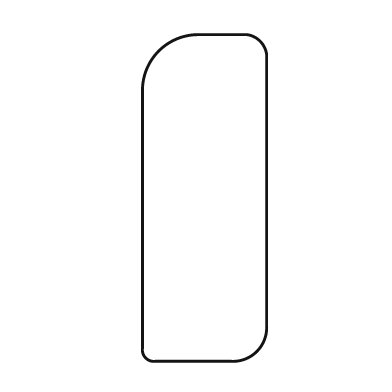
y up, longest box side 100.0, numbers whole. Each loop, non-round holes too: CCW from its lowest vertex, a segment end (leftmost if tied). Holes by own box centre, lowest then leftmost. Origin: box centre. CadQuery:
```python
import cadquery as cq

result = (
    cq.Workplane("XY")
    .moveTo(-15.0, -50.0)
    .lineTo(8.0, -50.0)
    .threePointArc((16.0, -47.0), (19.0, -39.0))
    .lineTo(19.0, 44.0)
    .threePointArc((17.0, 48.0), (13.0, 50.0))
    .lineTo(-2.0, 50.0)
    .threePointArc((-14.0, 45.0), (-19.0, 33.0))
    .lineTo(-19.0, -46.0)
    .threePointArc((-18.0, -49.0), (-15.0, -50.0))
    .close()
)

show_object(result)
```